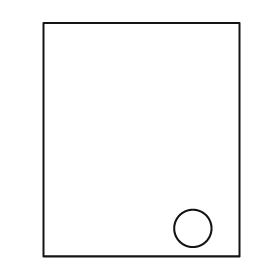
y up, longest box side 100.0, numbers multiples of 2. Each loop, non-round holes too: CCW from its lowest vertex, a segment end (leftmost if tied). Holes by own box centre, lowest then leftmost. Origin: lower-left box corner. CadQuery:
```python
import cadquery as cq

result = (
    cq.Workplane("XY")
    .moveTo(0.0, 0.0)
    .lineTo(84.0, 0.0)
    .lineTo(84.0, 100.0)
    .lineTo(0.0, 100.0)
    .close()
    .moveTo(64.0, 12.0)
    .circle(8.0)
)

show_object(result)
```